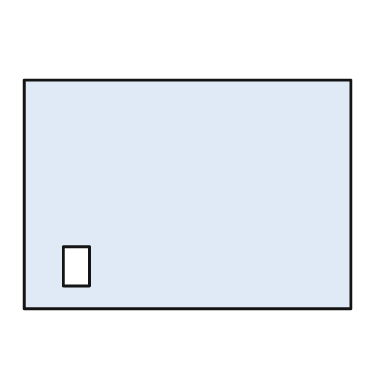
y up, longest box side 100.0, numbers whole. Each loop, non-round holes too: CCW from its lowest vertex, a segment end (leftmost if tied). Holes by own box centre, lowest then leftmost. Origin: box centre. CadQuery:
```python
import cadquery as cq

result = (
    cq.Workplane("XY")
    .moveTo(-50.0, -35.0)
    .lineTo(50.0, -35.0)
    .lineTo(50.0, 35.0)
    .lineTo(-50.0, 35.0)
    .close()
    .moveTo(-38.0, -28.0)
    .lineTo(-30.0, -28.0)
    .lineTo(-30.0, -16.0)
    .lineTo(-38.0, -16.0)
    .close()
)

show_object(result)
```